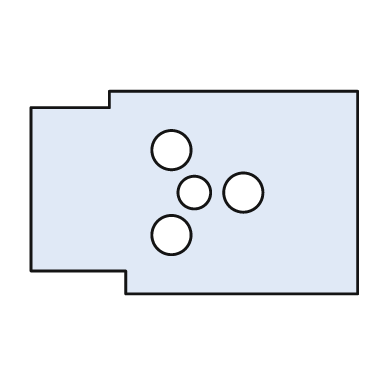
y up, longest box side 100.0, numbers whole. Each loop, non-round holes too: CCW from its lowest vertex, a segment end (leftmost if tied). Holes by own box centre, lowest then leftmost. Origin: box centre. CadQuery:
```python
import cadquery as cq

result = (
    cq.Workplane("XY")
    .moveTo(-21.0, -31.0)
    .lineTo(50.0, -31.0)
    .lineTo(50.0, 31.0)
    .lineTo(-26.0, 31.0)
    .lineTo(-26.0, 26.0)
    .lineTo(-50.0, 26.0)
    .lineTo(-50.0, -24.0)
    .lineTo(-21.0, -24.0)
    .close()
    .moveTo(-7.0, -13.0)
    .circle(6.0)
    .moveTo(0.0, 0.0)
    .circle(5.0)
    .moveTo(15.0, 0.0)
    .circle(6.0)
    .moveTo(-7.0, 13.0)
    .circle(6.0)
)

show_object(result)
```